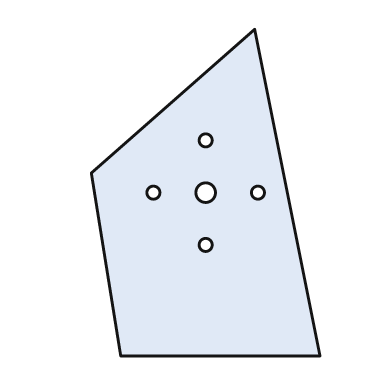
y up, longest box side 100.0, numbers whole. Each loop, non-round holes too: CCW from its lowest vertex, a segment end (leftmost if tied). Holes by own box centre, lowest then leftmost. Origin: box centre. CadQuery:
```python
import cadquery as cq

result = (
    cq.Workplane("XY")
    .moveTo(-26.0, -50.0)
    .lineTo(35.0, -50.0)
    .lineTo(15.0, 50.0)
    .lineTo(-35.0, 6.0)
    .close()
    .moveTo(0.0, -16.0)
    .circle(2.0)
    .moveTo(-16.0, 0.0)
    .circle(2.0)
    .moveTo(0.0, 0.0)
    .circle(3.0)
    .moveTo(16.0, 0.0)
    .circle(2.0)
    .moveTo(0.0, 16.0)
    .circle(2.0)
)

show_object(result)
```